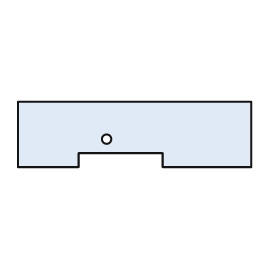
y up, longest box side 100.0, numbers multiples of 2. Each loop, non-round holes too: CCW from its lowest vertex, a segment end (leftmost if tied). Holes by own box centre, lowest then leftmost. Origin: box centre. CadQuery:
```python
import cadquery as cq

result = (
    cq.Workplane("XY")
    .moveTo(-50.0, -14.0)
    .lineTo(-24.0, -14.0)
    .lineTo(-24.0, -8.0)
    .lineTo(12.0, -8.0)
    .lineTo(12.0, -14.0)
    .lineTo(50.0, -14.0)
    .lineTo(50.0, 14.0)
    .lineTo(-50.0, 14.0)
    .close()
    .moveTo(-12.0, -2.0)
    .circle(2.0)
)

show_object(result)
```